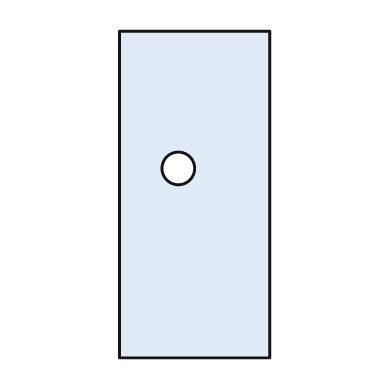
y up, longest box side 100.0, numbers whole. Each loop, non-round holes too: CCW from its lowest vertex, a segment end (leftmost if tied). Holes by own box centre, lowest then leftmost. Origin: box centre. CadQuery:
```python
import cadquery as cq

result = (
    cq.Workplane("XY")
    .moveTo(-23.0, -50.0)
    .lineTo(23.0, -50.0)
    .lineTo(23.0, 50.0)
    .lineTo(-23.0, 50.0)
    .close()
    .moveTo(-5.0, 8.0)
    .circle(5.0)
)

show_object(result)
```